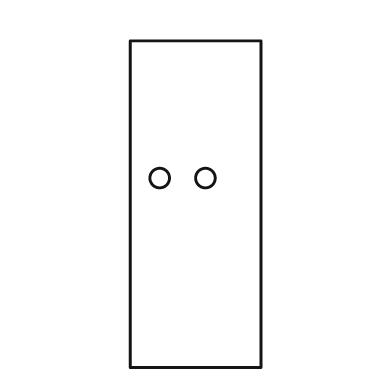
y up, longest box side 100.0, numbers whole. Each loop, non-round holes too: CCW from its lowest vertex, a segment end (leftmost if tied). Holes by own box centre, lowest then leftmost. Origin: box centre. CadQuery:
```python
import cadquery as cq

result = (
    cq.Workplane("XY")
    .moveTo(-20.0, -50.0)
    .lineTo(20.0, -50.0)
    .lineTo(20.0, 50.0)
    .lineTo(-20.0, 50.0)
    .close()
    .moveTo(-11.0, 8.0)
    .circle(3.0)
    .moveTo(3.0, 8.0)
    .circle(3.0)
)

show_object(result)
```